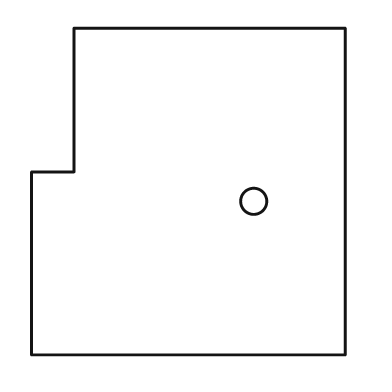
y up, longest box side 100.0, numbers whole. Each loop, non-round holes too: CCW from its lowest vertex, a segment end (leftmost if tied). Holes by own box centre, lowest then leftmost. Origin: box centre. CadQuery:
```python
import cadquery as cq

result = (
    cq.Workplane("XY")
    .moveTo(-48.0, -50.0)
    .lineTo(48.0, -50.0)
    .lineTo(48.0, 50.0)
    .lineTo(-35.0, 50.0)
    .lineTo(-35.0, 6.0)
    .lineTo(-48.0, 6.0)
    .close()
    .moveTo(20.0, -3.0)
    .circle(4.0)
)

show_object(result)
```